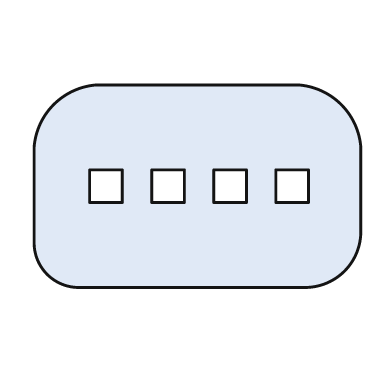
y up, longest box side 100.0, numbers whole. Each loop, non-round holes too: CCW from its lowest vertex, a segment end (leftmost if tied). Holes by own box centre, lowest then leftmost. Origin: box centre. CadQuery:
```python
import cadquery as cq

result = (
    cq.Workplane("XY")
    .moveTo(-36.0, -31.0)
    .lineTo(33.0, -31.0)
    .threePointArc((45.0, -26.0), (50.0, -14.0))
    .lineTo(50.0, 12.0)
    .threePointArc((44.0, 25.0), (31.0, 31.0))
    .lineTo(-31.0, 31.0)
    .threePointArc((-44.0, 25.0), (-50.0, 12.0))
    .lineTo(-50.0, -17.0)
    .threePointArc((-46.0, -27.0), (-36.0, -31.0))
    .close()
    .moveTo(-33.0, -5.0)
    .lineTo(-23.0, -5.0)
    .lineTo(-23.0, 5.0)
    .lineTo(-33.0, 5.0)
    .close()
    .moveTo(-14.0, -5.0)
    .lineTo(-4.0, -5.0)
    .lineTo(-4.0, 5.0)
    .lineTo(-14.0, 5.0)
    .close()
    .moveTo(5.0, -5.0)
    .lineTo(15.0, -5.0)
    .lineTo(15.0, 5.0)
    .lineTo(5.0, 5.0)
    .close()
    .moveTo(24.0, -5.0)
    .lineTo(34.0, -5.0)
    .lineTo(34.0, 5.0)
    .lineTo(24.0, 5.0)
    .close()
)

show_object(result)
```